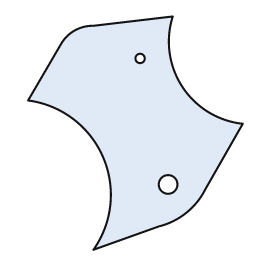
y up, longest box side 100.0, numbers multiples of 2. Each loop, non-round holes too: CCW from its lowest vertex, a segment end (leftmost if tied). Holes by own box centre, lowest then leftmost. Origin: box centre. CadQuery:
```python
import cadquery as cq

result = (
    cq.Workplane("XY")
    .moveTo(-18.0, -50.0)
    .lineTo(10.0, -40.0)
    .threePointArc((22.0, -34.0), (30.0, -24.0))
    .lineTo(46.0, 4.0)
    .threePointArc((20.0, 20.0), (16.0, 50.0))
    .lineTo(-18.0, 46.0)
    .threePointArc((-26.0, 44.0), (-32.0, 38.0))
    .lineTo(-46.0, 14.0)
    .threePointArc((-14.0, -10.0), (-18.0, -50.0))
    .close()
    .moveTo(14.0, -22.0)
    .circle(4.0)
    .moveTo(2.0, 32.0)
    .circle(2.0)
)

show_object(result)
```